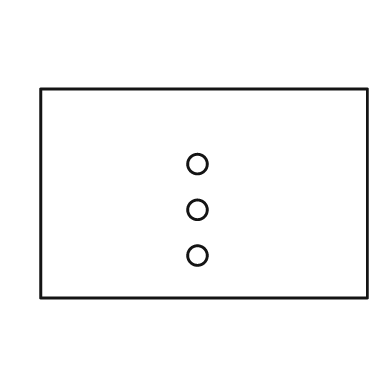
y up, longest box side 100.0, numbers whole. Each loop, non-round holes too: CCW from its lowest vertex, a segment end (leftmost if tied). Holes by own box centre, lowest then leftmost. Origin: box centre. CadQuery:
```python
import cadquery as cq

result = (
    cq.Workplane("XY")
    .moveTo(-50.0, -32.0)
    .lineTo(50.0, -32.0)
    .lineTo(50.0, 32.0)
    .lineTo(-50.0, 32.0)
    .close()
    .moveTo(-2.0, -19.0)
    .circle(3.0)
    .moveTo(-2.0, -5.0)
    .circle(3.0)
    .moveTo(-2.0, 9.0)
    .circle(3.0)
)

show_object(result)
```